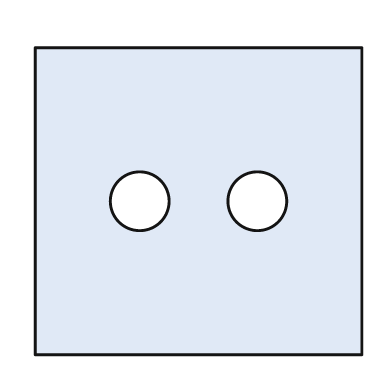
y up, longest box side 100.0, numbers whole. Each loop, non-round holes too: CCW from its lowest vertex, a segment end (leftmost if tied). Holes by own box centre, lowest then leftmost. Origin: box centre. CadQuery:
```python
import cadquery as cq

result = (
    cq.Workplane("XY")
    .moveTo(-50.0, -47.0)
    .lineTo(50.0, -47.0)
    .lineTo(50.0, 47.0)
    .lineTo(-50.0, 47.0)
    .close()
    .moveTo(-18.0, 0.0)
    .circle(9.0)
    .moveTo(18.0, 0.0)
    .circle(9.0)
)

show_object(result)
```